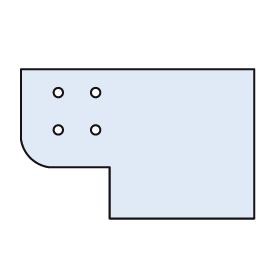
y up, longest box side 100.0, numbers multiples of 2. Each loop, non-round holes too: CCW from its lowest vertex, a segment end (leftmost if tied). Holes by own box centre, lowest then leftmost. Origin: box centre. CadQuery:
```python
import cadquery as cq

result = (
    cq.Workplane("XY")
    .moveTo(-12.0, -32.0)
    .lineTo(50.0, -32.0)
    .lineTo(50.0, 32.0)
    .lineTo(-50.0, 32.0)
    .lineTo(-50.0, 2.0)
    .threePointArc((-46.0, -6.0), (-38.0, -10.0))
    .lineTo(-12.0, -10.0)
    .close()
    .moveTo(-34.0, 6.0)
    .circle(2.0)
    .moveTo(-18.0, 6.0)
    .circle(2.0)
    .moveTo(-34.0, 22.0)
    .circle(2.0)
    .moveTo(-18.0, 22.0)
    .circle(2.0)
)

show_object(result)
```